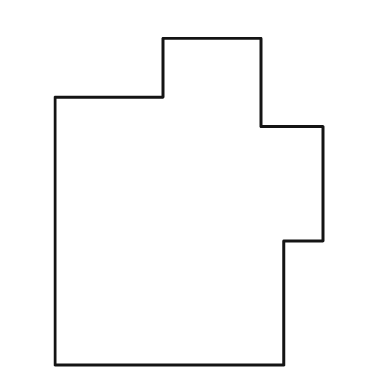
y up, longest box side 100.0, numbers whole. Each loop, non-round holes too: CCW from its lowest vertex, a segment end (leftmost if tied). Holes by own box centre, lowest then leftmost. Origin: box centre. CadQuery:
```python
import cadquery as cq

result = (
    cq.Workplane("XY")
    .moveTo(-41.0, -50.0)
    .lineTo(29.0, -50.0)
    .lineTo(29.0, -12.0)
    .lineTo(41.0, -12.0)
    .lineTo(41.0, 23.0)
    .lineTo(22.0, 23.0)
    .lineTo(22.0, 50.0)
    .lineTo(-8.0, 50.0)
    .lineTo(-8.0, 32.0)
    .lineTo(-41.0, 32.0)
    .close()
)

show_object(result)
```